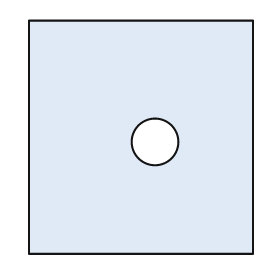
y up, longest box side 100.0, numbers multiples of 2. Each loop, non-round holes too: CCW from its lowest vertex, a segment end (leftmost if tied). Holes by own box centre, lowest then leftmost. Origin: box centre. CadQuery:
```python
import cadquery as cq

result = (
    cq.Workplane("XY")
    .moveTo(-48.0, -50.0)
    .lineTo(48.0, -50.0)
    .lineTo(48.0, 50.0)
    .lineTo(-48.0, 50.0)
    .close()
    .moveTo(6.0, -2.0)
    .circle(10.0)
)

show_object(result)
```